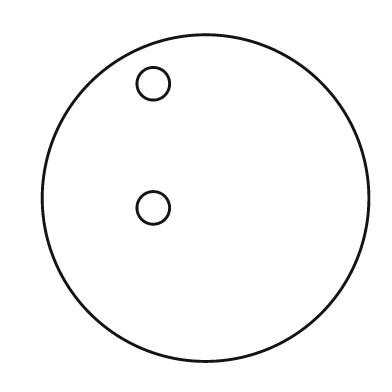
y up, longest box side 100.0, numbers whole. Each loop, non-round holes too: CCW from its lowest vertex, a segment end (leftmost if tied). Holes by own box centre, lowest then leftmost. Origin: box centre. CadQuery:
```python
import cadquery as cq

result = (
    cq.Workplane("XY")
    .moveTo(0.0, 0.0)
    .circle(50.0)
    .moveTo(-16.0, -3.0)
    .circle(5.0)
    .moveTo(-16.0, 35.0)
    .circle(5.0)
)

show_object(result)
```